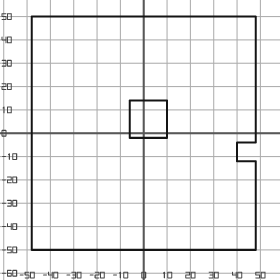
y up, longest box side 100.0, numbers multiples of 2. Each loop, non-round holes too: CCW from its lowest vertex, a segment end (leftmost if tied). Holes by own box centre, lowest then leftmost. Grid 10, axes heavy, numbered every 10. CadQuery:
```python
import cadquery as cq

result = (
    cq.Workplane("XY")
    .moveTo(-48.0, -50.0)
    .lineTo(48.0, -50.0)
    .lineTo(48.0, -12.0)
    .lineTo(40.0, -12.0)
    .lineTo(40.0, -4.0)
    .lineTo(48.0, -4.0)
    .lineTo(48.0, 50.0)
    .lineTo(-48.0, 50.0)
    .close()
    .moveTo(-6.0, -2.0)
    .lineTo(10.0, -2.0)
    .lineTo(10.0, 14.0)
    .lineTo(-6.0, 14.0)
    .close()
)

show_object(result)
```